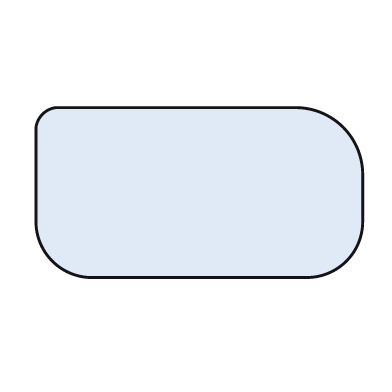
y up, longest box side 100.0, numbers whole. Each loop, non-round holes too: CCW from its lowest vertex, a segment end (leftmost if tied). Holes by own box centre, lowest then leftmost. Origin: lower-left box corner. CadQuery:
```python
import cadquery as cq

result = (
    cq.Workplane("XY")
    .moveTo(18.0, 0.0)
    .lineTo(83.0, 0.0)
    .threePointArc((95.0, 5.0), (100.0, 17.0))
    .lineTo(100.0, 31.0)
    .threePointArc((94.0, 46.0), (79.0, 52.0))
    .lineTo(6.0, 52.0)
    .threePointArc((2.0, 50.0), (0.0, 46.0))
    .lineTo(0.0, 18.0)
    .threePointArc((5.0, 5.0), (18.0, 0.0))
    .close()
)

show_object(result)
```